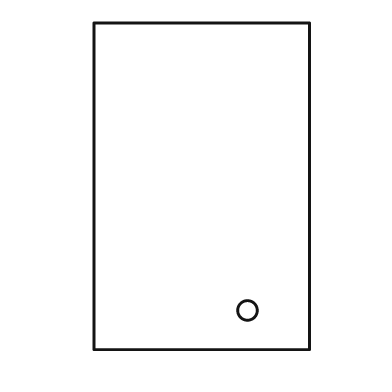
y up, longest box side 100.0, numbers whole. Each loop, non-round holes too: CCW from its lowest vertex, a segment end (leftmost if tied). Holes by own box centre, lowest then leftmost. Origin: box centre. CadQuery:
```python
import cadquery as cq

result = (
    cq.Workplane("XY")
    .moveTo(-33.0, -50.0)
    .lineTo(33.0, -50.0)
    .lineTo(33.0, 50.0)
    .lineTo(-33.0, 50.0)
    .close()
    .moveTo(14.0, -38.0)
    .circle(3.0)
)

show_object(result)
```